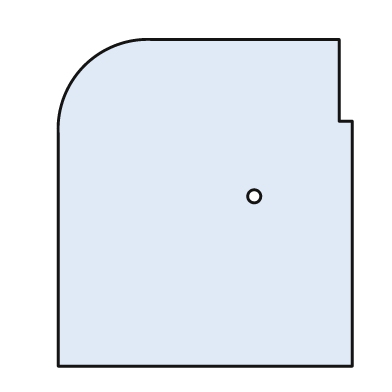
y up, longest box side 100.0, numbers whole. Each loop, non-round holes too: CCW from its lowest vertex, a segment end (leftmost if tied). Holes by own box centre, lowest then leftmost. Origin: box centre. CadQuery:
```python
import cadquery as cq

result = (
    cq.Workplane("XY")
    .moveTo(-45.0, -50.0)
    .lineTo(45.0, -50.0)
    .lineTo(45.0, 25.0)
    .lineTo(41.0, 25.0)
    .lineTo(41.0, 50.0)
    .lineTo(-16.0, 50.0)
    .threePointArc((-37.0, 42.0), (-45.0, 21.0))
    .close()
    .moveTo(15.0, 2.0)
    .circle(2.0)
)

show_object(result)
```